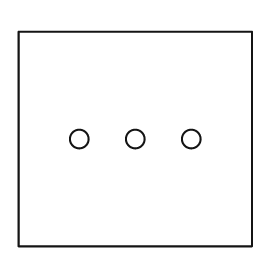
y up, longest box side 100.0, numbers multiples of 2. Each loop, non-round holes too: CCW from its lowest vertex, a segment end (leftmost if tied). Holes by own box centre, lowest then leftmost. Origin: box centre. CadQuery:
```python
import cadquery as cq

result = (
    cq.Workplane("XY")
    .moveTo(-50.0, -46.0)
    .lineTo(50.0, -46.0)
    .lineTo(50.0, 46.0)
    .lineTo(-50.0, 46.0)
    .close()
    .moveTo(-24.0, 0.0)
    .circle(4.0)
    .moveTo(0.0, 0.0)
    .circle(4.0)
    .moveTo(24.0, 0.0)
    .circle(4.0)
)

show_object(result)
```